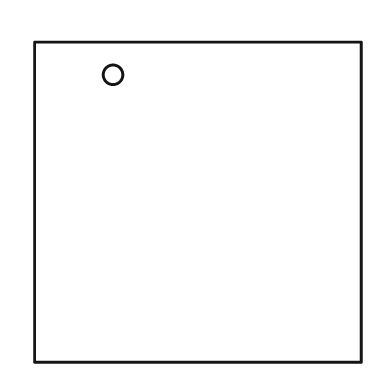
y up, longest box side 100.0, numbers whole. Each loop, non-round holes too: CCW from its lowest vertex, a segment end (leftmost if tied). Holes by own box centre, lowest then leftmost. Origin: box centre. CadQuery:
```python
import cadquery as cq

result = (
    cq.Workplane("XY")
    .moveTo(-50.0, -49.0)
    .lineTo(50.0, -49.0)
    .lineTo(50.0, 49.0)
    .lineTo(-50.0, 49.0)
    .close()
    .moveTo(-26.0, 39.0)
    .circle(3.0)
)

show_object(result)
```